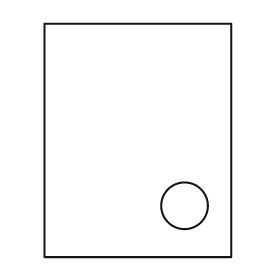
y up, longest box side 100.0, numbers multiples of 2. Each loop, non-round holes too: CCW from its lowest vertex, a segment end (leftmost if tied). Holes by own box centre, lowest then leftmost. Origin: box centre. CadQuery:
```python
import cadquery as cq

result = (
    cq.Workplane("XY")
    .moveTo(-40.0, -50.0)
    .lineTo(40.0, -50.0)
    .lineTo(40.0, 50.0)
    .lineTo(-40.0, 50.0)
    .close()
    .moveTo(20.0, -28.0)
    .circle(10.0)
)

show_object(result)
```